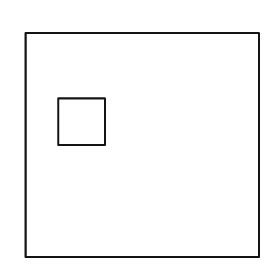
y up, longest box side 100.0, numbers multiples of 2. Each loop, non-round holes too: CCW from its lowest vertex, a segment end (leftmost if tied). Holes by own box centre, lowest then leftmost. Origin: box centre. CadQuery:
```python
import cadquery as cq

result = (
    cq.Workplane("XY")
    .moveTo(-50.0, -48.0)
    .lineTo(50.0, -48.0)
    .lineTo(50.0, 48.0)
    .lineTo(-50.0, 48.0)
    .close()
    .moveTo(-36.0, 0.0)
    .lineTo(-16.0, 0.0)
    .lineTo(-16.0, 20.0)
    .lineTo(-36.0, 20.0)
    .close()
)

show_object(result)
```